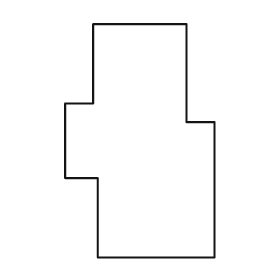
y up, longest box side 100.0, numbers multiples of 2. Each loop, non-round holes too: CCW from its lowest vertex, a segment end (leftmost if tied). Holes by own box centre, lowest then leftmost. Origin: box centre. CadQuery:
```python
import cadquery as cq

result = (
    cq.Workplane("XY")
    .moveTo(-18.0, -50.0)
    .lineTo(32.0, -50.0)
    .lineTo(32.0, 8.0)
    .lineTo(20.0, 8.0)
    .lineTo(20.0, 50.0)
    .lineTo(-20.0, 50.0)
    .lineTo(-20.0, 16.0)
    .lineTo(-32.0, 16.0)
    .lineTo(-32.0, -16.0)
    .lineTo(-18.0, -16.0)
    .close()
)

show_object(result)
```